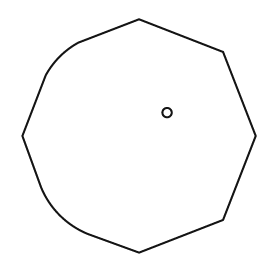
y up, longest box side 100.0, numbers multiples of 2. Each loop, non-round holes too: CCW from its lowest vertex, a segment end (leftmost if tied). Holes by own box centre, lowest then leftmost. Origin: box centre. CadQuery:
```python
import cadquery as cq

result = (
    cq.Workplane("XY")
    .moveTo(0.0, -50.0)
    .lineTo(36.0, -36.0)
    .lineTo(50.0, 0.0)
    .lineTo(36.0, 36.0)
    .lineTo(0.0, 50.0)
    .lineTo(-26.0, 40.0)
    .threePointArc((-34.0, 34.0), (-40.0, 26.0))
    .lineTo(-50.0, 0.0)
    .lineTo(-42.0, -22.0)
    .threePointArc((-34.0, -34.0), (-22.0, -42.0))
    .close()
    .moveTo(12.0, 10.0)
    .circle(2.0)
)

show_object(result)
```